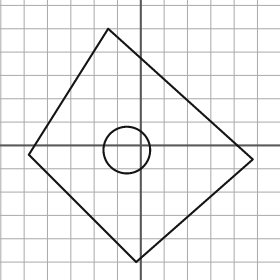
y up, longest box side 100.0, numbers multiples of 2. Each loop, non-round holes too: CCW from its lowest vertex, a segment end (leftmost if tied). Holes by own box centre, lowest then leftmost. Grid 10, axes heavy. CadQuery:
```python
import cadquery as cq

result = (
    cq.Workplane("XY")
    .moveTo(-2.0, -50.0)
    .lineTo(48.0, -6.0)
    .lineTo(-14.0, 50.0)
    .lineTo(-48.0, -4.0)
    .close()
    .moveTo(-6.0, -2.0)
    .circle(10.0)
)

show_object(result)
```